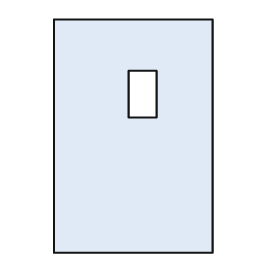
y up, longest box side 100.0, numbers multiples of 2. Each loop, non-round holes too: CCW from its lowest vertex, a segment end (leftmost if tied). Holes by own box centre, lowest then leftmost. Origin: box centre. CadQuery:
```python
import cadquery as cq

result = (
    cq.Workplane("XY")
    .moveTo(-34.0, -50.0)
    .lineTo(34.0, -50.0)
    .lineTo(34.0, 50.0)
    .lineTo(-34.0, 50.0)
    .close()
    .moveTo(-2.0, 8.0)
    .lineTo(10.0, 8.0)
    .lineTo(10.0, 28.0)
    .lineTo(-2.0, 28.0)
    .close()
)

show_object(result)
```